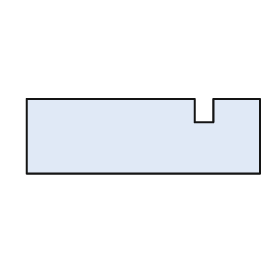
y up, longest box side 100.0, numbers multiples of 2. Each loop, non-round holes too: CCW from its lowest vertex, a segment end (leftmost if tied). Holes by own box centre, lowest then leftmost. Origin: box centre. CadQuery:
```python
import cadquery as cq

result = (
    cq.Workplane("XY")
    .moveTo(-50.0, -16.0)
    .lineTo(50.0, -16.0)
    .lineTo(50.0, 16.0)
    .lineTo(30.0, 16.0)
    .lineTo(30.0, 6.0)
    .lineTo(22.0, 6.0)
    .lineTo(22.0, 16.0)
    .lineTo(-50.0, 16.0)
    .close()
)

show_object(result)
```